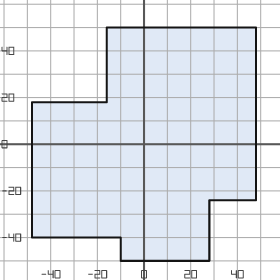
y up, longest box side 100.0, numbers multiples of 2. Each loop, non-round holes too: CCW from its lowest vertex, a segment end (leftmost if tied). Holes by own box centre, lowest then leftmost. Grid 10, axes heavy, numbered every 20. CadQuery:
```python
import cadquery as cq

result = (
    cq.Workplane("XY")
    .moveTo(-10.0, -50.0)
    .lineTo(28.0, -50.0)
    .lineTo(28.0, -24.0)
    .lineTo(48.0, -24.0)
    .lineTo(48.0, 50.0)
    .lineTo(-16.0, 50.0)
    .lineTo(-16.0, 18.0)
    .lineTo(-48.0, 18.0)
    .lineTo(-48.0, -40.0)
    .lineTo(-10.0, -40.0)
    .close()
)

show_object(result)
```